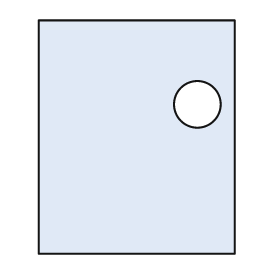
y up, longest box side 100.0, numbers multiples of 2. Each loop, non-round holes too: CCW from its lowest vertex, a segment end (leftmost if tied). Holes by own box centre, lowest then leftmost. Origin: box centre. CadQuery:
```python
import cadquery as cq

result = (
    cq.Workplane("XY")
    .moveTo(-42.0, -50.0)
    .lineTo(42.0, -50.0)
    .lineTo(42.0, 50.0)
    .lineTo(-42.0, 50.0)
    .close()
    .moveTo(26.0, 14.0)
    .circle(10.0)
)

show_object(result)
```